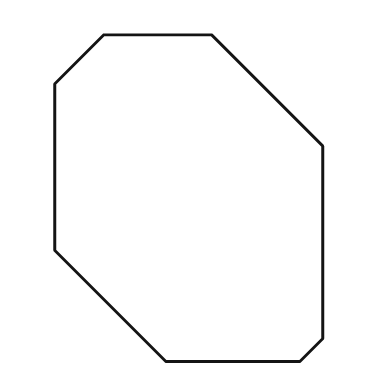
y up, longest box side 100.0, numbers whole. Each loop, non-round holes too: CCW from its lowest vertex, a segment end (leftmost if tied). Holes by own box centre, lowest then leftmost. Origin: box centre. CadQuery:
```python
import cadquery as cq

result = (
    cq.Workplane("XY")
    .moveTo(-7.0, -50.0)
    .lineTo(34.0, -50.0)
    .lineTo(41.0, -43.0)
    .lineTo(41.0, 16.0)
    .lineTo(7.0, 50.0)
    .lineTo(-26.0, 50.0)
    .lineTo(-41.0, 35.0)
    .lineTo(-41.0, -16.0)
    .close()
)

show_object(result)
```